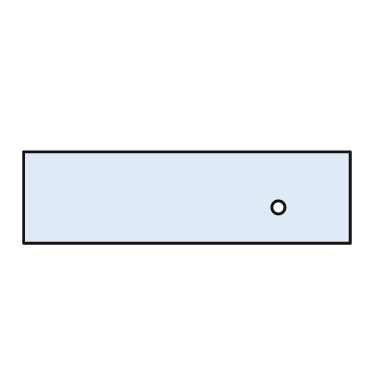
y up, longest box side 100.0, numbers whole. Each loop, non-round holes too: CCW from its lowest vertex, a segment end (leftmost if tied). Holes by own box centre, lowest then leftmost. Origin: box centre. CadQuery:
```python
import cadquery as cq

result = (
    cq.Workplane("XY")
    .moveTo(-50.0, -14.0)
    .lineTo(50.0, -14.0)
    .lineTo(50.0, 14.0)
    .lineTo(-50.0, 14.0)
    .close()
    .moveTo(28.0, -3.0)
    .circle(2.0)
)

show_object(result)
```